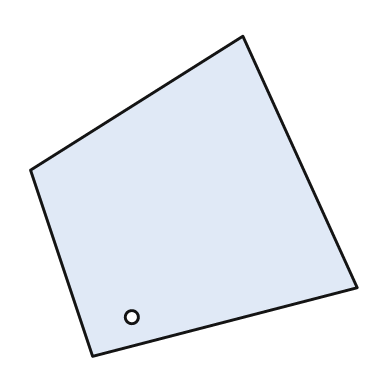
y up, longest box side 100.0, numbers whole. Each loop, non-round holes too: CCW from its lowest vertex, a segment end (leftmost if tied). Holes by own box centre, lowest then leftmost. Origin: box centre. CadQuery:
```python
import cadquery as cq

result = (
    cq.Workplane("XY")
    .moveTo(-31.0, -49.0)
    .lineTo(50.0, -28.0)
    .lineTo(15.0, 49.0)
    .lineTo(-50.0, 8.0)
    .close()
    .moveTo(-19.0, -37.0)
    .circle(2.0)
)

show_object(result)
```